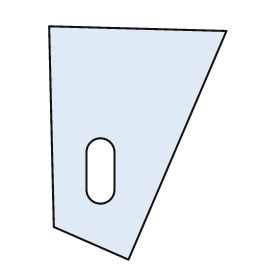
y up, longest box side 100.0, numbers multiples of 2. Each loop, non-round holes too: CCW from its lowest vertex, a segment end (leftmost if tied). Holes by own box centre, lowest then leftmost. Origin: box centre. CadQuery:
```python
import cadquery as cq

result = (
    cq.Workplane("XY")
    .moveTo(-4.0, -50.0)
    .lineTo(38.0, 48.0)
    .lineTo(-38.0, 50.0)
    .lineTo(-36.0, -36.0)
    .close()
    .moveTo(-22.0, -20.0)
    .threePointArc((-16.0, -26.0), (-10.0, -20.0))
    .lineTo(-10.0, -4.0)
    .threePointArc((-16.0, 2.0), (-22.0, -4.0))
    .close()
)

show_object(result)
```